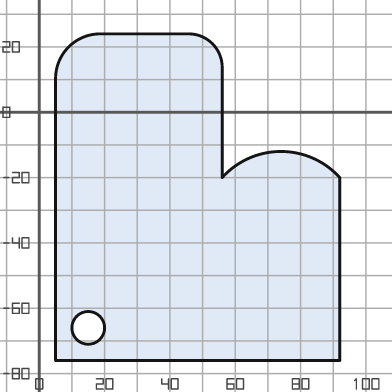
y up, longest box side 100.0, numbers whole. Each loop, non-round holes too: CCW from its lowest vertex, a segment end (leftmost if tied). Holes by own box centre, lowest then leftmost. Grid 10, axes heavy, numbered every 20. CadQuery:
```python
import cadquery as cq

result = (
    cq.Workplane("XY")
    .moveTo(5.0, -76.0)
    .lineTo(92.0, -76.0)
    .lineTo(92.0, -20.0)
    .threePointArc((74.0, -12.0), (56.0, -20.0))
    .lineTo(56.0, 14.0)
    .threePointArc((53.0, 21.0), (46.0, 24.0))
    .lineTo(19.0, 24.0)
    .threePointArc((9.0, 20.0), (5.0, 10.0))
    .close()
    .moveTo(15.0, -66.0)
    .circle(5.0)
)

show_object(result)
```